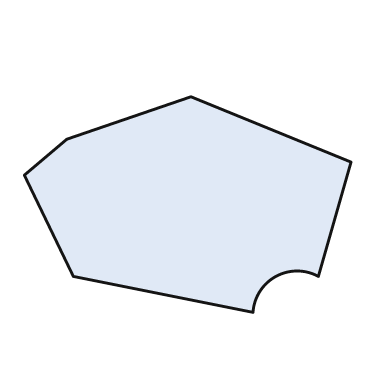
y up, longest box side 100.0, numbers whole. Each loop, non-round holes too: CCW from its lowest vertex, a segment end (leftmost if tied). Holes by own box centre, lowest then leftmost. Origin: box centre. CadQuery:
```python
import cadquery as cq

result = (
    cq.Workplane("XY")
    .moveTo(20.0, -33.0)
    .threePointArc((27.0, -22.0), (40.0, -22.0))
    .lineTo(50.0, 13.0)
    .lineTo(1.0, 33.0)
    .lineTo(-37.0, 20.0)
    .lineTo(-50.0, 9.0)
    .lineTo(-35.0, -22.0)
    .close()
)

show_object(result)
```